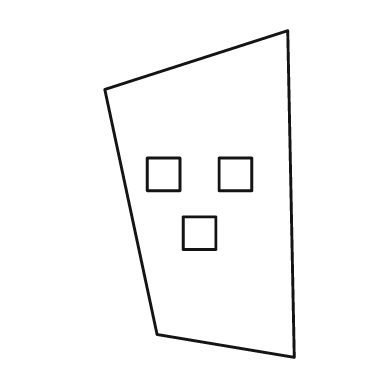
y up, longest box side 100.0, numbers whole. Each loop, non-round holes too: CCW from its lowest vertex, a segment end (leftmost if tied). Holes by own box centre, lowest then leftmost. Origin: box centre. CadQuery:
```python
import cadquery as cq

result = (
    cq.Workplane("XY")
    .moveTo(29.0, -50.0)
    .lineTo(27.0, 50.0)
    .lineTo(-29.0, 32.0)
    .lineTo(-13.0, -43.0)
    .close()
    .moveTo(-5.0, -17.0)
    .lineTo(5.0, -17.0)
    .lineTo(5.0, -7.0)
    .lineTo(-5.0, -7.0)
    .close()
    .moveTo(-16.0, 1.0)
    .lineTo(-6.0, 1.0)
    .lineTo(-6.0, 11.0)
    .lineTo(-16.0, 11.0)
    .close()
    .moveTo(6.0, 1.0)
    .lineTo(16.0, 1.0)
    .lineTo(16.0, 11.0)
    .lineTo(6.0, 11.0)
    .close()
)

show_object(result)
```